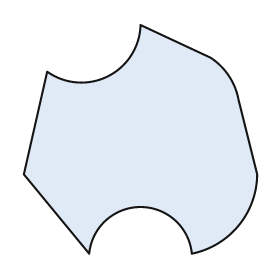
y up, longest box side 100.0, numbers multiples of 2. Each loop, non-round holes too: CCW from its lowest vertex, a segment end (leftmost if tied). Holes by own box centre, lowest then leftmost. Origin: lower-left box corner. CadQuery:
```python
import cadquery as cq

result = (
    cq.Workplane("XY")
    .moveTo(28.0, 0.0)
    .threePointArc((50.0, 20.0), (72.0, 0.0))
    .threePointArc((92.0, 12.0), (100.0, 34.0))
    .lineTo(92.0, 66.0)
    .threePointArc((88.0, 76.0), (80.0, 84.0))
    .lineTo(50.0, 98.0)
    .threePointArc((36.0, 76.0), (10.0, 78.0))
    .lineTo(0.0, 34.0)
    .close()
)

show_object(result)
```